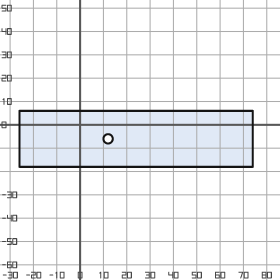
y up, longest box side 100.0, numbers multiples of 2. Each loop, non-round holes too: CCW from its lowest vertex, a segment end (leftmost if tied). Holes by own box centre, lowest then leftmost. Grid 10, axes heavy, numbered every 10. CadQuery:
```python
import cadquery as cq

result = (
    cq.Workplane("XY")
    .moveTo(-26.0, -18.0)
    .lineTo(74.0, -18.0)
    .lineTo(74.0, 6.0)
    .lineTo(-26.0, 6.0)
    .close()
    .moveTo(12.0, -6.0)
    .circle(2.0)
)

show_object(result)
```